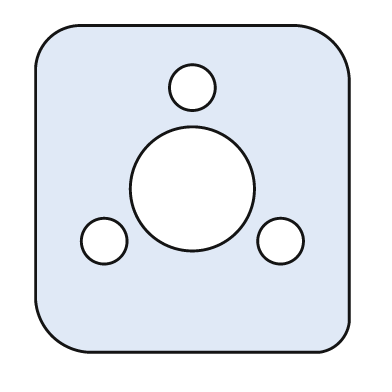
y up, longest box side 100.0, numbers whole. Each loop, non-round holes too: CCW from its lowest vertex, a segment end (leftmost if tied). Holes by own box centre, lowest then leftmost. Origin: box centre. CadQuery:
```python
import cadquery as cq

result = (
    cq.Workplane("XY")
    .moveTo(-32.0, -50.0)
    .lineTo(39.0, -50.0)
    .threePointArc((45.0, -47.0), (48.0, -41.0))
    .lineTo(48.0, 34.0)
    .threePointArc((43.0, 45.0), (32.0, 50.0))
    .lineTo(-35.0, 50.0)
    .threePointArc((-44.0, 46.0), (-48.0, 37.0))
    .lineTo(-48.0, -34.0)
    .threePointArc((-43.0, -45.0), (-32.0, -50.0))
    .close()
    .moveTo(-27.0, -16.0)
    .circle(7.0)
    .moveTo(27.0, -16.0)
    .circle(7.0)
    .moveTo(0.0, 0.0)
    .circle(19.0)
    .moveTo(0.0, 31.0)
    .circle(7.0)
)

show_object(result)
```